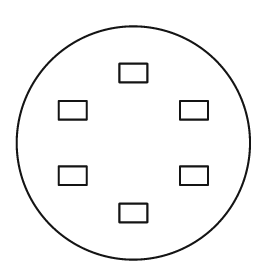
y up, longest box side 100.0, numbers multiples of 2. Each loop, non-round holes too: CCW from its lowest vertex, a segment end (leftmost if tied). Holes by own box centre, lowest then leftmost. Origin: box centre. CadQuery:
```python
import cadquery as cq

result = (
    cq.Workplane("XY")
    .moveTo(0.0, 0.0)
    .circle(50.0)
    .moveTo(-6.0, -34.0)
    .lineTo(6.0, -34.0)
    .lineTo(6.0, -26.0)
    .lineTo(-6.0, -26.0)
    .close()
    .moveTo(-32.0, -18.0)
    .lineTo(-20.0, -18.0)
    .lineTo(-20.0, -10.0)
    .lineTo(-32.0, -10.0)
    .close()
    .moveTo(20.0, -18.0)
    .lineTo(32.0, -18.0)
    .lineTo(32.0, -10.0)
    .lineTo(20.0, -10.0)
    .close()
    .moveTo(-32.0, 10.0)
    .lineTo(-20.0, 10.0)
    .lineTo(-20.0, 18.0)
    .lineTo(-32.0, 18.0)
    .close()
    .moveTo(20.0, 10.0)
    .lineTo(32.0, 10.0)
    .lineTo(32.0, 18.0)
    .lineTo(20.0, 18.0)
    .close()
    .moveTo(-6.0, 26.0)
    .lineTo(6.0, 26.0)
    .lineTo(6.0, 34.0)
    .lineTo(-6.0, 34.0)
    .close()
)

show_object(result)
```